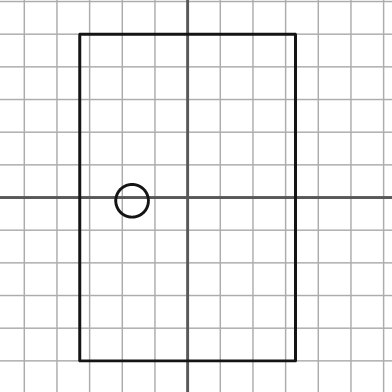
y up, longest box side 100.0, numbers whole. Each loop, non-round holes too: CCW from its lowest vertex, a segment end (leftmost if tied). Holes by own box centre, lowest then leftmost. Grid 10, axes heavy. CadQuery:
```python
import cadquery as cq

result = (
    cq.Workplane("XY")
    .moveTo(-33.0, -50.0)
    .lineTo(33.0, -50.0)
    .lineTo(33.0, 50.0)
    .lineTo(-33.0, 50.0)
    .close()
    .moveTo(-17.0, -1.0)
    .circle(5.0)
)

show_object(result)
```